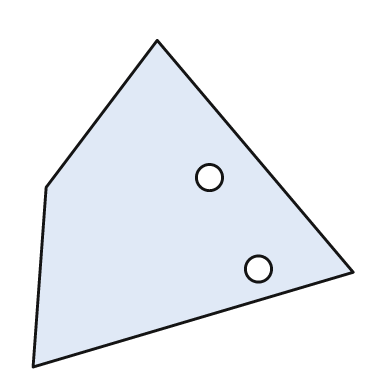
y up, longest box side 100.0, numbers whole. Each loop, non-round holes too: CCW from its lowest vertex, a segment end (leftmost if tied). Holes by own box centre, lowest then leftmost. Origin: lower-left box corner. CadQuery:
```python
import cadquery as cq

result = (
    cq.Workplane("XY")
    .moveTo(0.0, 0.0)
    .lineTo(98.0, 29.0)
    .lineTo(38.0, 100.0)
    .lineTo(4.0, 55.0)
    .close()
    .moveTo(69.0, 30.0)
    .circle(4.0)
    .moveTo(54.0, 58.0)
    .circle(4.0)
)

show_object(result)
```